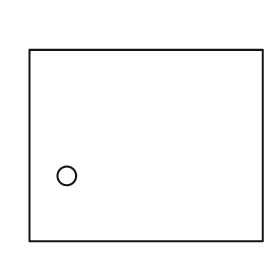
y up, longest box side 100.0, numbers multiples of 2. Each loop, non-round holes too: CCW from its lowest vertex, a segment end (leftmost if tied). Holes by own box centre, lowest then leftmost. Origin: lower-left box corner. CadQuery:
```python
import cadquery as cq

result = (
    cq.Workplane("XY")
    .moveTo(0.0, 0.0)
    .lineTo(100.0, 0.0)
    .lineTo(100.0, 82.0)
    .lineTo(0.0, 82.0)
    .close()
    .moveTo(16.0, 28.0)
    .circle(4.0)
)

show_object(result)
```